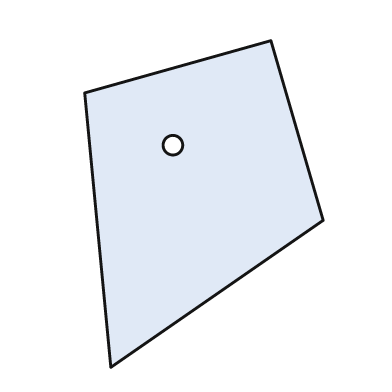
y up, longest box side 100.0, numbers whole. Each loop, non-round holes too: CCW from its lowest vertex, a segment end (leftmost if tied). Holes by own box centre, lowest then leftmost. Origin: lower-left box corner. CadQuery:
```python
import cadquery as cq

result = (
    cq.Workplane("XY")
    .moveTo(8.0, 0.0)
    .lineTo(73.0, 45.0)
    .lineTo(57.0, 100.0)
    .lineTo(0.0, 84.0)
    .close()
    .moveTo(27.0, 68.0)
    .circle(3.0)
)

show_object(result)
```